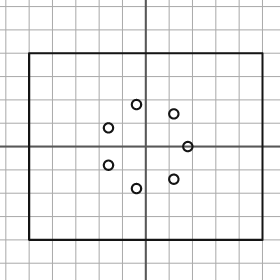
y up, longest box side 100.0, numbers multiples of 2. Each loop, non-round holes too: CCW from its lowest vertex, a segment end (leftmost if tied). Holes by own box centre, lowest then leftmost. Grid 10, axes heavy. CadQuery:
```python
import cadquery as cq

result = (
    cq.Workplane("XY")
    .moveTo(-50.0, -40.0)
    .lineTo(50.0, -40.0)
    .lineTo(50.0, 40.0)
    .lineTo(-50.0, 40.0)
    .close()
    .moveTo(-4.0, -18.0)
    .circle(2.0)
    .moveTo(12.0, -14.0)
    .circle(2.0)
    .moveTo(-16.0, -8.0)
    .circle(2.0)
    .moveTo(18.0, 0.0)
    .circle(2.0)
    .moveTo(-16.0, 8.0)
    .circle(2.0)
    .moveTo(12.0, 14.0)
    .circle(2.0)
    .moveTo(-4.0, 18.0)
    .circle(2.0)
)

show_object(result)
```